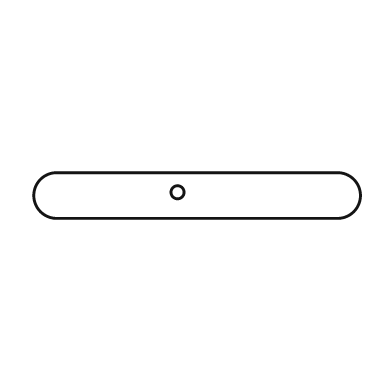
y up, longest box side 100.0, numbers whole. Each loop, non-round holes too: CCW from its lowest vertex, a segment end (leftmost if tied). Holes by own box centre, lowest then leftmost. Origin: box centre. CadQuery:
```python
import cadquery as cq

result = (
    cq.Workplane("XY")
    .moveTo(-43.0, -7.0)
    .lineTo(43.0, -7.0)
    .threePointArc((50.0, 0.0), (43.0, 7.0))
    .lineTo(-43.0, 7.0)
    .threePointArc((-50.0, 0.0), (-43.0, -7.0))
    .close()
    .moveTo(-6.0, 1.0)
    .circle(2.0)
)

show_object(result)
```